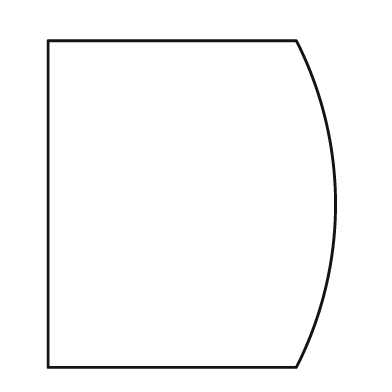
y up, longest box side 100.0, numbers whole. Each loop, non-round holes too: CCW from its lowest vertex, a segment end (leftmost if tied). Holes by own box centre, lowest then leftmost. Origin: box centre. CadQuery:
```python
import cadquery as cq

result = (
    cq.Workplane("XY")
    .moveTo(-44.0, -50.0)
    .lineTo(32.0, -50.0)
    .threePointArc((44.0, 0.0), (32.0, 50.0))
    .lineTo(-44.0, 50.0)
    .close()
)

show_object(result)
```